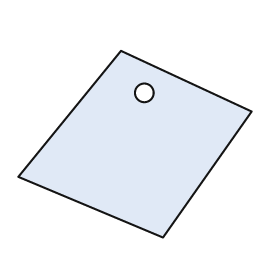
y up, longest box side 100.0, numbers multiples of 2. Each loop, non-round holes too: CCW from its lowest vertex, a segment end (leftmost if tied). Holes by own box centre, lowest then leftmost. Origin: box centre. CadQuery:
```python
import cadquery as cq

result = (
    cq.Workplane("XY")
    .moveTo(12.0, -40.0)
    .lineTo(50.0, 14.0)
    .lineTo(-6.0, 40.0)
    .lineTo(-50.0, -14.0)
    .close()
    .moveTo(4.0, 22.0)
    .circle(4.0)
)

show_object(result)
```